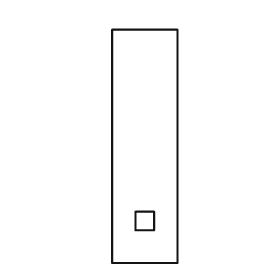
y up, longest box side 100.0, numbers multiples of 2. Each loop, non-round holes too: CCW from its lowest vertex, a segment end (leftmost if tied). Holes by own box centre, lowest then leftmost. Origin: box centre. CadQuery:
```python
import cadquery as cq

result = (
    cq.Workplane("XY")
    .moveTo(-14.0, -50.0)
    .lineTo(14.0, -50.0)
    .lineTo(14.0, 50.0)
    .lineTo(-14.0, 50.0)
    .close()
    .moveTo(-4.0, -36.0)
    .lineTo(4.0, -36.0)
    .lineTo(4.0, -28.0)
    .lineTo(-4.0, -28.0)
    .close()
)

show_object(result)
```